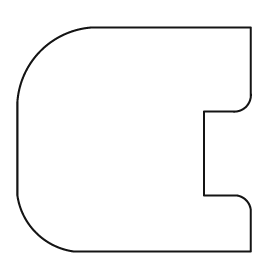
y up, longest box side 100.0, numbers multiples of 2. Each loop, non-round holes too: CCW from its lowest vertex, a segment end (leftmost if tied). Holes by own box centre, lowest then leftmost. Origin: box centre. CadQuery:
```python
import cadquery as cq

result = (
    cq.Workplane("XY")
    .moveTo(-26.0, -48.0)
    .lineTo(50.0, -48.0)
    .lineTo(50.0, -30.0)
    .threePointArc((48.0, -26.0), (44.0, -24.0))
    .lineTo(30.0, -24.0)
    .lineTo(30.0, 12.0)
    .lineTo(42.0, 12.0)
    .threePointArc((48.0, 14.0), (50.0, 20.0))
    .lineTo(50.0, 48.0)
    .lineTo(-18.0, 48.0)
    .threePointArc((-40.0, 38.0), (-50.0, 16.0))
    .lineTo(-50.0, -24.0)
    .threePointArc((-42.0, -40.0), (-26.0, -48.0))
    .close()
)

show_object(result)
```